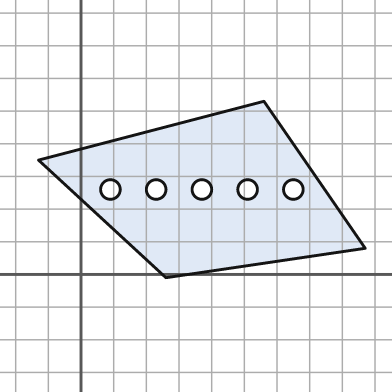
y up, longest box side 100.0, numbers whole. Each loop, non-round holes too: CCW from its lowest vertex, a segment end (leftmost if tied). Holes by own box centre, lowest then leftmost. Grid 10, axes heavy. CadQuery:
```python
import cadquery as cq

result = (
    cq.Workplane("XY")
    .moveTo(26.0, -1.0)
    .lineTo(87.0, 8.0)
    .lineTo(56.0, 53.0)
    .lineTo(-13.0, 35.0)
    .close()
    .moveTo(9.0, 26.0)
    .circle(3.0)
    .moveTo(23.0, 26.0)
    .circle(3.0)
    .moveTo(37.0, 26.0)
    .circle(3.0)
    .moveTo(51.0, 26.0)
    .circle(3.0)
    .moveTo(65.0, 26.0)
    .circle(3.0)
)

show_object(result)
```